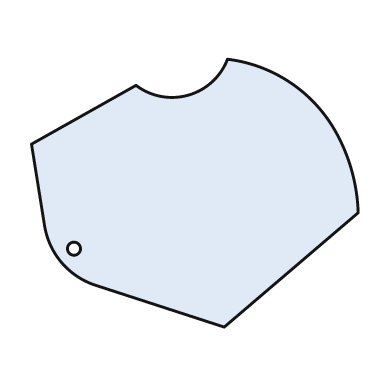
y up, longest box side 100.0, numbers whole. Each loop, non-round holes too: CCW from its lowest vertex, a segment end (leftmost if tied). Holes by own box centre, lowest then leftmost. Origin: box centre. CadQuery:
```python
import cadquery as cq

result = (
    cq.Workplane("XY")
    .moveTo(9.0, -41.0)
    .lineTo(50.0, -6.0)
    .threePointArc((48.0, 7.0), (43.0, 19.0))
    .threePointArc((29.0, 34.0), (10.0, 41.0))
    .threePointArc((-2.0, 30.0), (-18.0, 33.0))
    .lineTo(-50.0, 15.0)
    .lineTo(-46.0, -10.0)
    .threePointArc((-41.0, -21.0), (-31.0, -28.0))
    .close()
    .moveTo(-37.0, -17.0)
    .circle(2.0)
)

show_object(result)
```